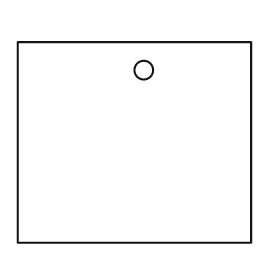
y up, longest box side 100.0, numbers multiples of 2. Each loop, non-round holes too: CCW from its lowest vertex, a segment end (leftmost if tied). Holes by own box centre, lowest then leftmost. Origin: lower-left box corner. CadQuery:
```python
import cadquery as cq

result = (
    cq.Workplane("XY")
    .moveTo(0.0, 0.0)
    .lineTo(100.0, 0.0)
    .lineTo(100.0, 86.0)
    .lineTo(0.0, 86.0)
    .close()
    .moveTo(54.0, 74.0)
    .circle(4.0)
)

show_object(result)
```